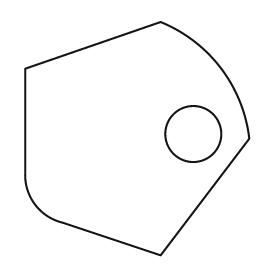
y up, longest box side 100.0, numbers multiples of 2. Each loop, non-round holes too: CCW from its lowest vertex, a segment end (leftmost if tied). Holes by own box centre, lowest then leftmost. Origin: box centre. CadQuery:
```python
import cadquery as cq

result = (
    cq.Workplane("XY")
    .moveTo(10.0, -50.0)
    .lineTo(48.0, 0.0)
    .threePointArc((36.0, 30.0), (10.0, 50.0))
    .lineTo(-48.0, 30.0)
    .lineTo(-48.0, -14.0)
    .threePointArc((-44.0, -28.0), (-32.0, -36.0))
    .close()
    .moveTo(24.0, 2.0)
    .circle(12.0)
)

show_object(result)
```